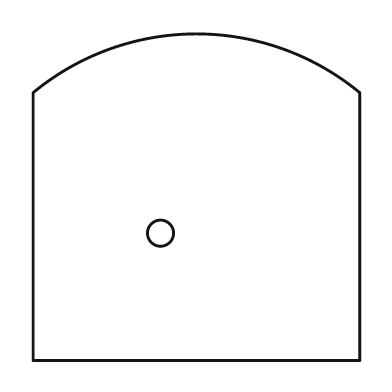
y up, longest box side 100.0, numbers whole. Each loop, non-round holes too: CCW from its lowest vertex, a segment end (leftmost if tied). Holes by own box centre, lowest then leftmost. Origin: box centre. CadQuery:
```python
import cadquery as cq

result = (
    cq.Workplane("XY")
    .moveTo(-50.0, -50.0)
    .lineTo(50.0, -50.0)
    .lineTo(50.0, 32.0)
    .threePointArc((0.0, 50.0), (-50.0, 32.0))
    .close()
    .moveTo(-11.0, -11.0)
    .circle(4.0)
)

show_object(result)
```